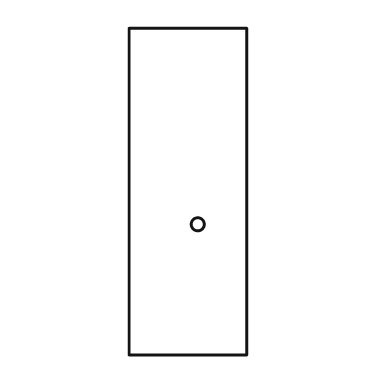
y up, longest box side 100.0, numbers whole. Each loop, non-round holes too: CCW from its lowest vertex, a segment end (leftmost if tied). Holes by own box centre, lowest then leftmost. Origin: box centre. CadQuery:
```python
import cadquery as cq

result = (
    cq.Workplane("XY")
    .moveTo(-18.0, -50.0)
    .lineTo(18.0, -50.0)
    .lineTo(18.0, 50.0)
    .lineTo(-18.0, 50.0)
    .close()
    .moveTo(3.0, -10.0)
    .circle(2.0)
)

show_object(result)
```